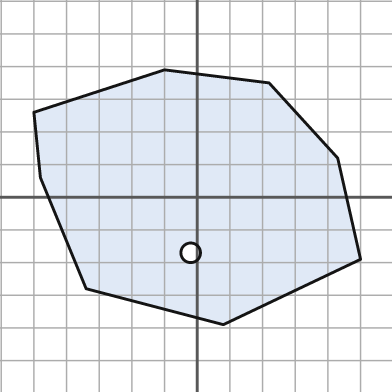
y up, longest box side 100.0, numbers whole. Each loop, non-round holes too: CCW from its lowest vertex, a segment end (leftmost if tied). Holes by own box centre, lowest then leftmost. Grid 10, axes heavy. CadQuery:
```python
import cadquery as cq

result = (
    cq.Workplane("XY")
    .moveTo(8.0, -39.0)
    .lineTo(50.0, -19.0)
    .lineTo(43.0, 12.0)
    .lineTo(22.0, 35.0)
    .lineTo(-10.0, 39.0)
    .lineTo(-50.0, 26.0)
    .lineTo(-48.0, 6.0)
    .lineTo(-34.0, -28.0)
    .close()
    .moveTo(-2.0, -17.0)
    .circle(3.0)
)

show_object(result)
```